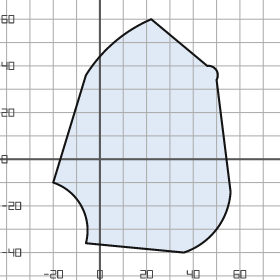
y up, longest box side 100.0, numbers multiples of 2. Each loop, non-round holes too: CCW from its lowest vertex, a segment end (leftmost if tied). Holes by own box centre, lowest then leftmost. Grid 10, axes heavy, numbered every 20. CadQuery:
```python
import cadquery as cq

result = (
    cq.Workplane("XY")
    .moveTo(36.0, -40.0)
    .threePointArc((50.0, -30.0), (56.0, -14.0))
    .lineTo(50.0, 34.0)
    .threePointArc((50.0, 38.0), (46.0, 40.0))
    .lineTo(22.0, 60.0)
    .threePointArc((6.0, 50.0), (-6.0, 36.0))
    .lineTo(-20.0, -10.0)
    .threePointArc((-8.0, -20.0), (-6.0, -36.0))
    .close()
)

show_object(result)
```